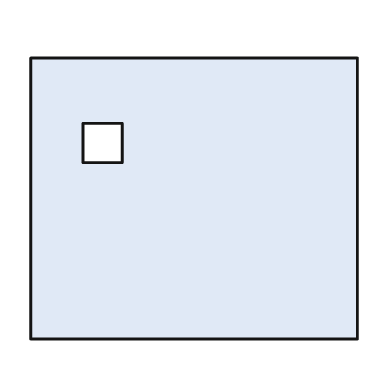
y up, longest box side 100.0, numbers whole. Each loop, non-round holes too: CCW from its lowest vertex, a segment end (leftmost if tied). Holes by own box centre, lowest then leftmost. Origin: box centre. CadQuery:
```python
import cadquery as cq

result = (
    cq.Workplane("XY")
    .moveTo(-50.0, -43.0)
    .lineTo(50.0, -43.0)
    .lineTo(50.0, 43.0)
    .lineTo(-50.0, 43.0)
    .close()
    .moveTo(-34.0, 11.0)
    .lineTo(-22.0, 11.0)
    .lineTo(-22.0, 23.0)
    .lineTo(-34.0, 23.0)
    .close()
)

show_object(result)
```